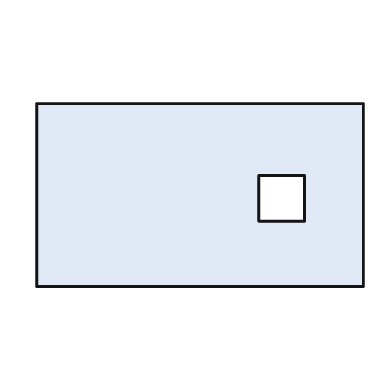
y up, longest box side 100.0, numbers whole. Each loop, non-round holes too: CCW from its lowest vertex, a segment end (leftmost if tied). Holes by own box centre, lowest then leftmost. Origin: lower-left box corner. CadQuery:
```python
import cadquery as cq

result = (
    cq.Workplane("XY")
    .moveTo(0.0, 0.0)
    .lineTo(100.0, 0.0)
    .lineTo(100.0, 56.0)
    .lineTo(0.0, 56.0)
    .close()
    .moveTo(68.0, 20.0)
    .lineTo(82.0, 20.0)
    .lineTo(82.0, 34.0)
    .lineTo(68.0, 34.0)
    .close()
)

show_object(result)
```